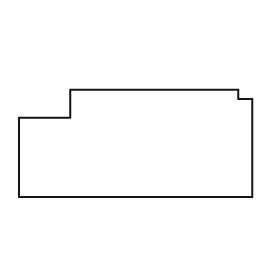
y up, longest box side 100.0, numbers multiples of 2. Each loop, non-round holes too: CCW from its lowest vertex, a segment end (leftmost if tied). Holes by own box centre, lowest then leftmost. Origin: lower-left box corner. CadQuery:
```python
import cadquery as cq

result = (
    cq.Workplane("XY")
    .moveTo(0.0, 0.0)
    .lineTo(100.0, 0.0)
    .lineTo(100.0, 42.0)
    .lineTo(94.0, 42.0)
    .lineTo(94.0, 46.0)
    .lineTo(22.0, 46.0)
    .lineTo(22.0, 34.0)
    .lineTo(0.0, 34.0)
    .close()
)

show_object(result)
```